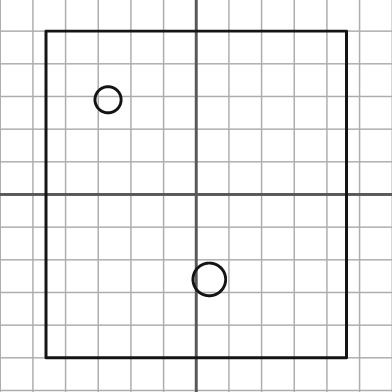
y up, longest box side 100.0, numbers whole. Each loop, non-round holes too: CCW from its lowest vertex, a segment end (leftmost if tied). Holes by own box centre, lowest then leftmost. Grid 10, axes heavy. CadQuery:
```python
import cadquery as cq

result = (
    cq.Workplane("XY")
    .moveTo(-46.0, -50.0)
    .lineTo(46.0, -50.0)
    .lineTo(46.0, 50.0)
    .lineTo(-46.0, 50.0)
    .close()
    .moveTo(4.0, -26.0)
    .circle(5.0)
    .moveTo(-27.0, 29.0)
    .circle(4.0)
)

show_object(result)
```